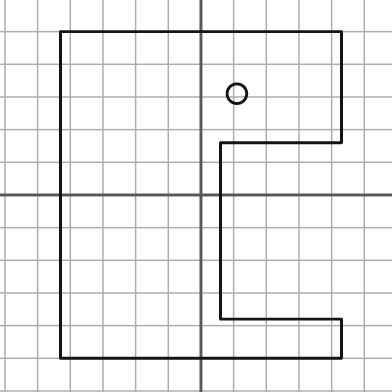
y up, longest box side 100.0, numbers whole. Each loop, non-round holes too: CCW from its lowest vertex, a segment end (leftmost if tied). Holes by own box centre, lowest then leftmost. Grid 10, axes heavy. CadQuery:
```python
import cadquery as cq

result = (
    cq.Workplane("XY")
    .moveTo(-43.0, -50.0)
    .lineTo(43.0, -50.0)
    .lineTo(43.0, -38.0)
    .lineTo(6.0, -38.0)
    .lineTo(6.0, 16.0)
    .lineTo(43.0, 16.0)
    .lineTo(43.0, 50.0)
    .lineTo(-43.0, 50.0)
    .close()
    .moveTo(11.0, 31.0)
    .circle(3.0)
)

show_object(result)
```